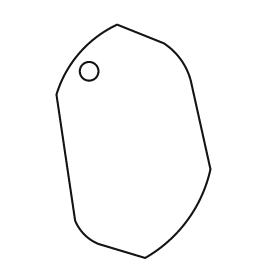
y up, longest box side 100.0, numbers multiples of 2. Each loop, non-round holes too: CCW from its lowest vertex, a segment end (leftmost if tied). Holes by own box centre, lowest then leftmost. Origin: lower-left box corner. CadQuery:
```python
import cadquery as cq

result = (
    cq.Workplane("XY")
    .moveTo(38.0, 0.0)
    .threePointArc((56.0, 16.0), (66.0, 38.0))
    .lineTo(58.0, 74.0)
    .threePointArc((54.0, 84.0), (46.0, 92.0))
    .lineTo(26.0, 100.0)
    .threePointArc((10.0, 88.0), (0.0, 70.0))
    .lineTo(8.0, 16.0)
    .threePointArc((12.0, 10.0), (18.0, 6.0))
    .close()
    .moveTo(14.0, 80.0)
    .circle(4.0)
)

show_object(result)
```